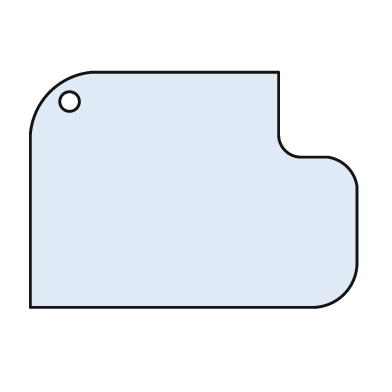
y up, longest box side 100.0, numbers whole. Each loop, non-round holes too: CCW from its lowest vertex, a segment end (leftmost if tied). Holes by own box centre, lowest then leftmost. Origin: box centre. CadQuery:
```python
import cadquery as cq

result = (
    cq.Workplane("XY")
    .moveTo(-50.0, -36.0)
    .lineTo(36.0, -36.0)
    .threePointArc((46.0, -32.0), (50.0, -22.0))
    .lineTo(50.0, 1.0)
    .threePointArc((47.0, 7.0), (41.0, 10.0))
    .lineTo(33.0, 10.0)
    .threePointArc((28.0, 12.0), (26.0, 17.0))
    .lineTo(26.0, 36.0)
    .lineTo(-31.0, 36.0)
    .threePointArc((-44.0, 30.0), (-50.0, 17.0))
    .close()
    .moveTo(-38.0, 27.0)
    .circle(3.0)
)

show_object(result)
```